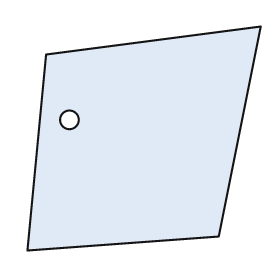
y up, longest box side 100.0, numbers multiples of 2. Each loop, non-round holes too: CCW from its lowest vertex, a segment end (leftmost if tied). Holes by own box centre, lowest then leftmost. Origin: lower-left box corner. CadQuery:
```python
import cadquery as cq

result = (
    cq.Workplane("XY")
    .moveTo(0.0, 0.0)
    .lineTo(82.0, 6.0)
    .lineTo(100.0, 96.0)
    .lineTo(8.0, 84.0)
    .close()
    .moveTo(18.0, 56.0)
    .circle(4.0)
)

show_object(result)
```